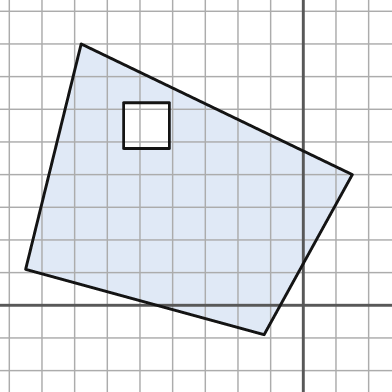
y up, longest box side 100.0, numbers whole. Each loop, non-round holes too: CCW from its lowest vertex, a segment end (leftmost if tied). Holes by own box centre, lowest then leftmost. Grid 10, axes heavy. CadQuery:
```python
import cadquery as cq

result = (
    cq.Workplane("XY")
    .moveTo(-12.0, -9.0)
    .lineTo(15.0, 40.0)
    .lineTo(-68.0, 80.0)
    .lineTo(-85.0, 11.0)
    .close()
    .moveTo(-55.0, 48.0)
    .lineTo(-41.0, 48.0)
    .lineTo(-41.0, 62.0)
    .lineTo(-55.0, 62.0)
    .close()
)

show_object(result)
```